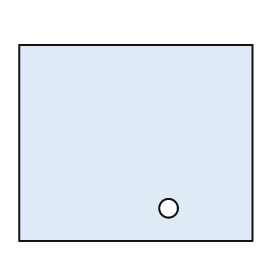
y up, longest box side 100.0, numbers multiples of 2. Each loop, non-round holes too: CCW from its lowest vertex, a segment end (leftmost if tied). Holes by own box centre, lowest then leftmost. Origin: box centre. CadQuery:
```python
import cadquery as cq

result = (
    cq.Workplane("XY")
    .moveTo(-50.0, -42.0)
    .lineTo(50.0, -42.0)
    .lineTo(50.0, 42.0)
    .lineTo(-50.0, 42.0)
    .close()
    .moveTo(14.0, -28.0)
    .circle(4.0)
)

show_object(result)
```